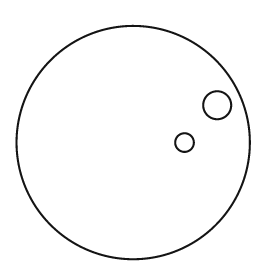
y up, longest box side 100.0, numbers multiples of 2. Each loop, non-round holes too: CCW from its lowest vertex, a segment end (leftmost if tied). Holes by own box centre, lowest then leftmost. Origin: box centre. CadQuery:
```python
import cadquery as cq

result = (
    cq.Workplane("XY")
    .moveTo(0.0, 0.0)
    .circle(50.0)
    .moveTo(22.0, 0.0)
    .circle(4.0)
    .moveTo(36.0, 16.0)
    .circle(6.0)
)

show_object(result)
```